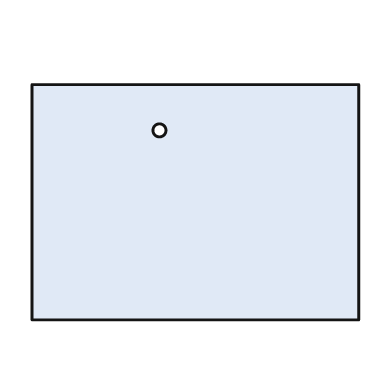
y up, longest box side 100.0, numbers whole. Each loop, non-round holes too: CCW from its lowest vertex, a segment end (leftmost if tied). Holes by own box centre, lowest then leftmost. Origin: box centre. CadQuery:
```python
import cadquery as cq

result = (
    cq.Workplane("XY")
    .moveTo(-50.0, -36.0)
    .lineTo(50.0, -36.0)
    .lineTo(50.0, 36.0)
    .lineTo(-50.0, 36.0)
    .close()
    .moveTo(-11.0, 22.0)
    .circle(2.0)
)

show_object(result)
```